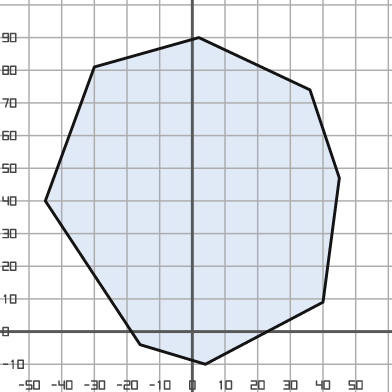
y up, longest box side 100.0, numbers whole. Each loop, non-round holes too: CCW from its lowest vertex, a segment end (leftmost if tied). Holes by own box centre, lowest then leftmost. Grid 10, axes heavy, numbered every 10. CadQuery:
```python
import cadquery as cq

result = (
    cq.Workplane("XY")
    .moveTo(4.0, -10.0)
    .lineTo(40.0, 9.0)
    .lineTo(45.0, 47.0)
    .lineTo(36.0, 74.0)
    .lineTo(2.0, 90.0)
    .lineTo(-30.0, 81.0)
    .lineTo(-45.0, 40.0)
    .lineTo(-16.0, -4.0)
    .close()
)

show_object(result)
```